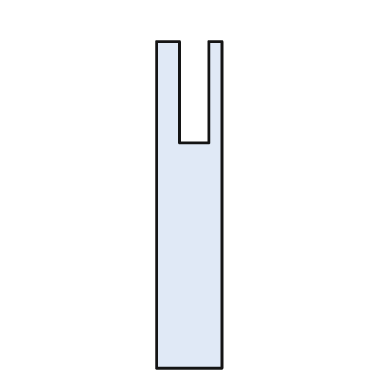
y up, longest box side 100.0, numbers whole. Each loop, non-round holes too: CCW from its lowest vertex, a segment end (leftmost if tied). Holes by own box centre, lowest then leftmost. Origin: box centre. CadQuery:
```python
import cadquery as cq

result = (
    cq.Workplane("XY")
    .moveTo(-10.0, -50.0)
    .lineTo(10.0, -50.0)
    .lineTo(10.0, 50.0)
    .lineTo(6.0, 50.0)
    .lineTo(6.0, 19.0)
    .lineTo(-3.0, 19.0)
    .lineTo(-3.0, 50.0)
    .lineTo(-10.0, 50.0)
    .close()
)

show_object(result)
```